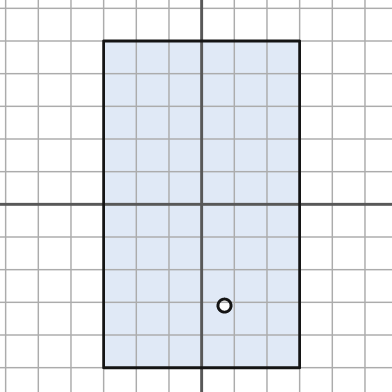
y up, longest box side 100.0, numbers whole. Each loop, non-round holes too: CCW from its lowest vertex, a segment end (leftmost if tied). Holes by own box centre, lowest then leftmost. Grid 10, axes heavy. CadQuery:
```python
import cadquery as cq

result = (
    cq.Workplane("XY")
    .moveTo(-30.0, -50.0)
    .lineTo(30.0, -50.0)
    .lineTo(30.0, 50.0)
    .lineTo(-30.0, 50.0)
    .close()
    .moveTo(7.0, -31.0)
    .circle(2.0)
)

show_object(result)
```